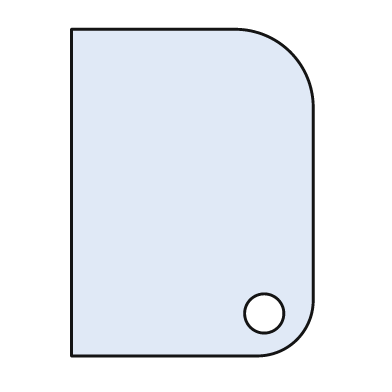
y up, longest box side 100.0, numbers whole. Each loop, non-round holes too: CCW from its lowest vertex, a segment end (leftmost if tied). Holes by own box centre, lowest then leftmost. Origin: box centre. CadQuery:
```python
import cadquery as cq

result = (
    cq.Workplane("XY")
    .moveTo(-37.0, -50.0)
    .lineTo(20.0, -50.0)
    .threePointArc((32.0, -45.0), (37.0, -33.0))
    .lineTo(37.0, 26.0)
    .threePointArc((30.0, 43.0), (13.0, 50.0))
    .lineTo(-37.0, 50.0)
    .close()
    .moveTo(22.0, -37.0)
    .circle(6.0)
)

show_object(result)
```